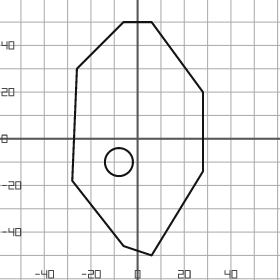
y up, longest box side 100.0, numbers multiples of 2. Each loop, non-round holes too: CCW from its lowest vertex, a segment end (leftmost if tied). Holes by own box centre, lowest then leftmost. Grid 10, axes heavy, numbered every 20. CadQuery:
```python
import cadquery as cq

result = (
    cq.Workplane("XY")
    .moveTo(6.0, -50.0)
    .lineTo(28.0, -14.0)
    .lineTo(28.0, 20.0)
    .lineTo(6.0, 50.0)
    .lineTo(-6.0, 50.0)
    .lineTo(-26.0, 30.0)
    .lineTo(-28.0, -18.0)
    .lineTo(-6.0, -46.0)
    .close()
    .moveTo(-8.0, -10.0)
    .circle(6.0)
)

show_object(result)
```